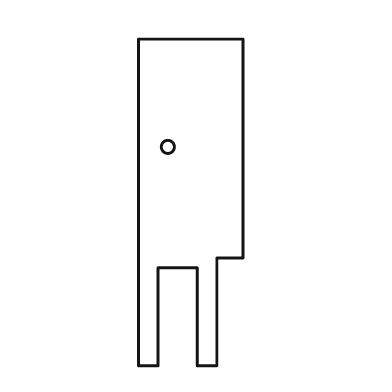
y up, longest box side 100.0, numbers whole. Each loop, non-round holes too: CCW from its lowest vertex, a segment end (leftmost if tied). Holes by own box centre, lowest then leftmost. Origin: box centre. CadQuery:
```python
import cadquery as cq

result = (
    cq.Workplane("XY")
    .moveTo(-16.0, -50.0)
    .lineTo(-10.0, -50.0)
    .lineTo(-10.0, -20.0)
    .lineTo(2.0, -20.0)
    .lineTo(2.0, -50.0)
    .lineTo(8.0, -50.0)
    .lineTo(8.0, -17.0)
    .lineTo(16.0, -17.0)
    .lineTo(16.0, 50.0)
    .lineTo(-16.0, 50.0)
    .close()
    .moveTo(-7.0, 17.0)
    .circle(2.0)
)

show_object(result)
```